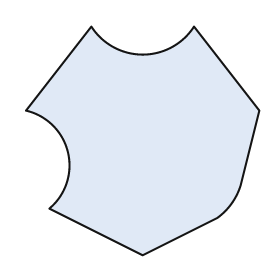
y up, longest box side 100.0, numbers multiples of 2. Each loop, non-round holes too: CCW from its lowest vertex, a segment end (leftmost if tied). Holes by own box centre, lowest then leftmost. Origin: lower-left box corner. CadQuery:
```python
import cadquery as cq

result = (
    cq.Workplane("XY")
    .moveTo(50.0, 0.0)
    .lineTo(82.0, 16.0)
    .threePointArc((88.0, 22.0), (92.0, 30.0))
    .lineTo(100.0, 62.0)
    .lineTo(72.0, 98.0)
    .threePointArc((50.0, 86.0), (28.0, 98.0))
    .lineTo(0.0, 62.0)
    .threePointArc((18.0, 44.0), (10.0, 20.0))
    .close()
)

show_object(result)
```